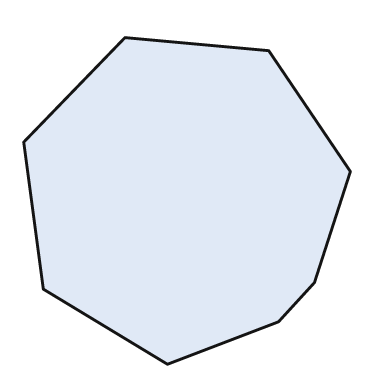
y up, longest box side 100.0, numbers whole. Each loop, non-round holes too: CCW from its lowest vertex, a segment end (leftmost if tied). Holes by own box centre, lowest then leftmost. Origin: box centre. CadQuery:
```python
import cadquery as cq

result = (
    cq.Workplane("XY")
    .moveTo(-6.0, -50.0)
    .lineTo(28.0, -37.0)
    .lineTo(39.0, -25.0)
    .lineTo(50.0, 9.0)
    .lineTo(25.0, 46.0)
    .lineTo(-19.0, 50.0)
    .lineTo(-50.0, 18.0)
    .lineTo(-44.0, -27.0)
    .close()
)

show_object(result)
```